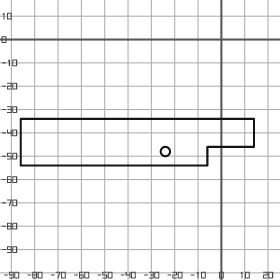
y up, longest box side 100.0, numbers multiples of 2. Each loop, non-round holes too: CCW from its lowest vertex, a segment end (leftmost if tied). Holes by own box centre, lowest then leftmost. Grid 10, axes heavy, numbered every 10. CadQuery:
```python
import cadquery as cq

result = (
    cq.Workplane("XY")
    .moveTo(-86.0, -54.0)
    .lineTo(-6.0, -54.0)
    .lineTo(-6.0, -46.0)
    .lineTo(14.0, -46.0)
    .lineTo(14.0, -34.0)
    .lineTo(-86.0, -34.0)
    .close()
    .moveTo(-24.0, -48.0)
    .circle(2.0)
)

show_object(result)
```